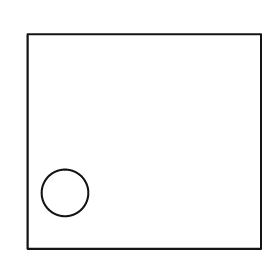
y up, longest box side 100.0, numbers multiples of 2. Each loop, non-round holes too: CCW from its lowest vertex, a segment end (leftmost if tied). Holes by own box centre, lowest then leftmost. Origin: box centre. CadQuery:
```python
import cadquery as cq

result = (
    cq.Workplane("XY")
    .moveTo(-50.0, -46.0)
    .lineTo(50.0, -46.0)
    .lineTo(50.0, 46.0)
    .lineTo(-50.0, 46.0)
    .close()
    .moveTo(-34.0, -22.0)
    .circle(10.0)
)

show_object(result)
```